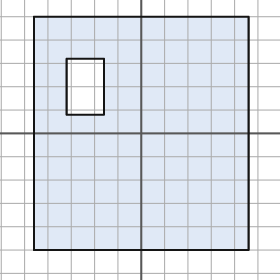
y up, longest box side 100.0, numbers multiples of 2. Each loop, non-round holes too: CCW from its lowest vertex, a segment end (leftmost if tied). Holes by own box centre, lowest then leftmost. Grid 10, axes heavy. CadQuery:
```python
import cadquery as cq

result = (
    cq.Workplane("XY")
    .moveTo(-46.0, -50.0)
    .lineTo(46.0, -50.0)
    .lineTo(46.0, 50.0)
    .lineTo(-46.0, 50.0)
    .close()
    .moveTo(-32.0, 8.0)
    .lineTo(-16.0, 8.0)
    .lineTo(-16.0, 32.0)
    .lineTo(-32.0, 32.0)
    .close()
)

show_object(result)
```